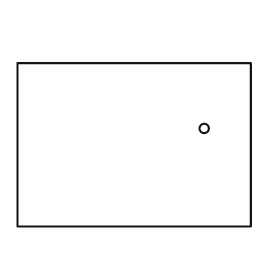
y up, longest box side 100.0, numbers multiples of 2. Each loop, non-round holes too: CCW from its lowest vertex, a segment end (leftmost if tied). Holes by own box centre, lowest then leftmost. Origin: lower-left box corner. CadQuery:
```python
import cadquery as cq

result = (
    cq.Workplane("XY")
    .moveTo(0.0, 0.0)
    .lineTo(100.0, 0.0)
    .lineTo(100.0, 70.0)
    .lineTo(0.0, 70.0)
    .close()
    .moveTo(80.0, 42.0)
    .circle(2.0)
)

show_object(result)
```